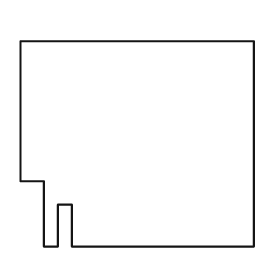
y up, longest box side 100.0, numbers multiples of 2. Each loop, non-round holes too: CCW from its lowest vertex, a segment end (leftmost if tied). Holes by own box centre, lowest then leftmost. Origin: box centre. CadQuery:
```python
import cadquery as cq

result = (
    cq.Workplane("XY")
    .moveTo(-40.0, -44.0)
    .lineTo(-34.0, -44.0)
    .lineTo(-34.0, -26.0)
    .lineTo(-28.0, -26.0)
    .lineTo(-28.0, -44.0)
    .lineTo(50.0, -44.0)
    .lineTo(50.0, 44.0)
    .lineTo(-50.0, 44.0)
    .lineTo(-50.0, -16.0)
    .lineTo(-40.0, -16.0)
    .close()
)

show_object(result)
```